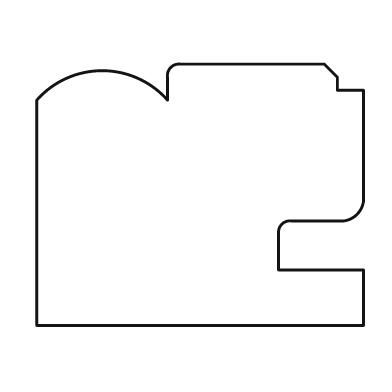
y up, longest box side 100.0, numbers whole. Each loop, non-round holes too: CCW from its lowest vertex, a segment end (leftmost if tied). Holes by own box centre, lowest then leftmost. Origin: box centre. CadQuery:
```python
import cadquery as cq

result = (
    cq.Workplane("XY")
    .moveTo(-50.0, -40.0)
    .lineTo(50.0, -40.0)
    .lineTo(50.0, -23.0)
    .lineTo(24.0, -23.0)
    .lineTo(24.0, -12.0)
    .threePointArc((25.0, -9.0), (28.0, -8.0))
    .lineTo(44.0, -8.0)
    .threePointArc((48.0, -6.0), (50.0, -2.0))
    .lineTo(50.0, 32.0)
    .lineTo(42.0, 32.0)
    .lineTo(42.0, 36.0)
    .lineTo(38.0, 40.0)
    .lineTo(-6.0, 40.0)
    .threePointArc((-9.0, 39.0), (-10.0, 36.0))
    .lineTo(-10.0, 29.0)
    .threePointArc((-30.0, 38.0), (-50.0, 29.0))
    .close()
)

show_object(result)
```